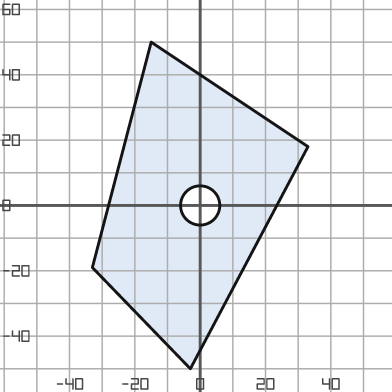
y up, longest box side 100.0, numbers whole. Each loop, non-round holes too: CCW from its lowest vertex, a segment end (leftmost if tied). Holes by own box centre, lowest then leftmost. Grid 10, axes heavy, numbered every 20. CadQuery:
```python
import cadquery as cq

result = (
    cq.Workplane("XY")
    .moveTo(-3.0, -50.0)
    .lineTo(33.0, 18.0)
    .lineTo(-15.0, 50.0)
    .lineTo(-33.0, -19.0)
    .close()
    .moveTo(0.0, 0.0)
    .circle(6.0)
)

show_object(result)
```